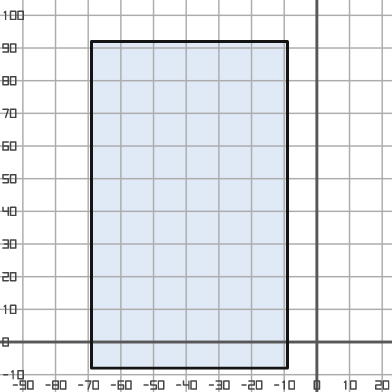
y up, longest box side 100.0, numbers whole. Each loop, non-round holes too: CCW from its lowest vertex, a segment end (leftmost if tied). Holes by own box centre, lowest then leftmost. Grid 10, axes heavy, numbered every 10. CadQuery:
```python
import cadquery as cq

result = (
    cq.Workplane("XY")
    .moveTo(-69.0, -8.0)
    .lineTo(-9.0, -8.0)
    .lineTo(-9.0, 92.0)
    .lineTo(-69.0, 92.0)
    .close()
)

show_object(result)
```